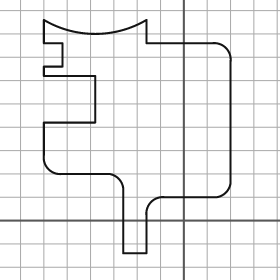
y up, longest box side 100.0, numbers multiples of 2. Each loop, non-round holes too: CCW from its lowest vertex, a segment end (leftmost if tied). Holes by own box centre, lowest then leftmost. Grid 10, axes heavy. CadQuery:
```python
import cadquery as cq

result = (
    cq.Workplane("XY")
    .moveTo(-26.0, -14.0)
    .lineTo(-16.0, -14.0)
    .lineTo(-16.0, 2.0)
    .threePointArc((-14.0, 8.0), (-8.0, 10.0))
    .lineTo(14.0, 10.0)
    .threePointArc((18.0, 12.0), (20.0, 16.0))
    .lineTo(20.0, 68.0)
    .threePointArc((18.0, 74.0), (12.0, 76.0))
    .lineTo(-16.0, 76.0)
    .lineTo(-16.0, 86.0)
    .threePointArc((-38.0, 80.0), (-60.0, 86.0))
    .lineTo(-60.0, 76.0)
    .lineTo(-52.0, 76.0)
    .lineTo(-52.0, 66.0)
    .lineTo(-60.0, 66.0)
    .lineTo(-60.0, 62.0)
    .lineTo(-38.0, 62.0)
    .lineTo(-38.0, 42.0)
    .lineTo(-60.0, 42.0)
    .lineTo(-60.0, 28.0)
    .threePointArc((-58.0, 22.0), (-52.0, 20.0))
    .lineTo(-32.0, 20.0)
    .threePointArc((-28.0, 18.0), (-26.0, 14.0))
    .close()
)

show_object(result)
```